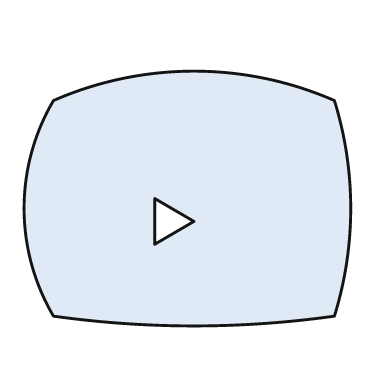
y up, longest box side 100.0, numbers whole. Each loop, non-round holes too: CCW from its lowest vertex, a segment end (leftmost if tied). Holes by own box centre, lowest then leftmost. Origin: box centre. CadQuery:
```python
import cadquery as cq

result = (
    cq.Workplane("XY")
    .moveTo(-41.0, -36.0)
    .threePointArc((2.0, -39.0), (45.0, -36.0))
    .threePointArc((50.0, -3.0), (45.0, 30.0))
    .threePointArc((2.0, 39.0), (-41.0, 30.0))
    .threePointArc((-50.0, -3.0), (-41.0, -36.0))
    .close()
    .moveTo(-10.0, -14.0)
    .lineTo(2.0, -7.0)
    .lineTo(-10.0, 0.0)
    .close()
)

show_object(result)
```